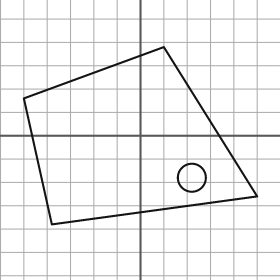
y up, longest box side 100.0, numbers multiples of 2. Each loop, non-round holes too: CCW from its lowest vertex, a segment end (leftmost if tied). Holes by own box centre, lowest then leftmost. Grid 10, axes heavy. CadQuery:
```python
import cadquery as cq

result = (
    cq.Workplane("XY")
    .moveTo(-38.0, -38.0)
    .lineTo(50.0, -26.0)
    .lineTo(10.0, 38.0)
    .lineTo(-50.0, 16.0)
    .close()
    .moveTo(22.0, -18.0)
    .circle(6.0)
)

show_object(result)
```